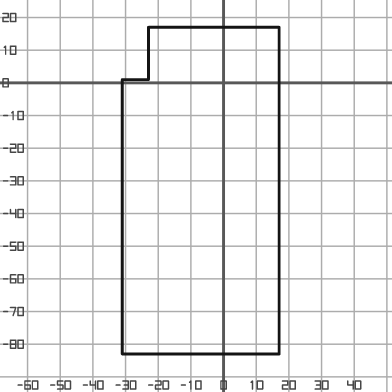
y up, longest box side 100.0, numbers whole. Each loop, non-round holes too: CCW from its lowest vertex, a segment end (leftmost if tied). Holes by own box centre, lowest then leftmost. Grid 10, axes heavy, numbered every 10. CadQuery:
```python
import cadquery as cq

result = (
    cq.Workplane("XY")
    .moveTo(-31.0, -83.0)
    .lineTo(17.0, -83.0)
    .lineTo(17.0, 17.0)
    .lineTo(-23.0, 17.0)
    .lineTo(-23.0, 1.0)
    .lineTo(-31.0, 1.0)
    .close()
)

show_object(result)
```